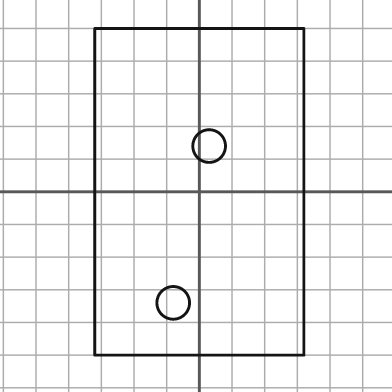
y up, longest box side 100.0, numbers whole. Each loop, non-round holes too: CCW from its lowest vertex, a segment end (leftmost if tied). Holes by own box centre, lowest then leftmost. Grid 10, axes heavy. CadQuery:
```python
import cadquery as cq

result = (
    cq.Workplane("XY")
    .moveTo(-32.0, -50.0)
    .lineTo(32.0, -50.0)
    .lineTo(32.0, 50.0)
    .lineTo(-32.0, 50.0)
    .close()
    .moveTo(-8.0, -34.0)
    .circle(5.0)
    .moveTo(3.0, 14.0)
    .circle(5.0)
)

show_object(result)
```